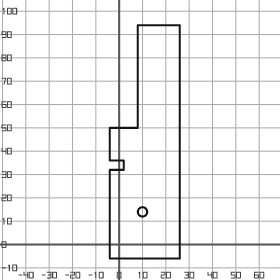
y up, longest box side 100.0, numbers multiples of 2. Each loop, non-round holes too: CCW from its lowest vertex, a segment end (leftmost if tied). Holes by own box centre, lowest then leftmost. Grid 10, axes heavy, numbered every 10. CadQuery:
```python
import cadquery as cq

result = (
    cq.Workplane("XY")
    .moveTo(-4.0, -6.0)
    .lineTo(26.0, -6.0)
    .lineTo(26.0, 94.0)
    .lineTo(8.0, 94.0)
    .lineTo(8.0, 50.0)
    .lineTo(-4.0, 50.0)
    .lineTo(-4.0, 36.0)
    .lineTo(2.0, 36.0)
    .lineTo(2.0, 32.0)
    .lineTo(-4.0, 32.0)
    .close()
    .moveTo(10.0, 14.0)
    .circle(2.0)
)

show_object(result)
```